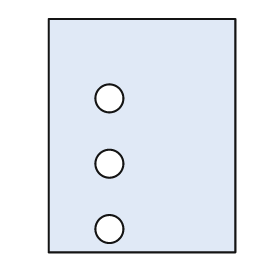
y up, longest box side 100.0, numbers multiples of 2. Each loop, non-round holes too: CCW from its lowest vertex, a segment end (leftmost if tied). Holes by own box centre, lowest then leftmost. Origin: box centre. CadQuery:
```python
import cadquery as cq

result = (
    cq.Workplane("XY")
    .moveTo(-40.0, -50.0)
    .lineTo(40.0, -50.0)
    .lineTo(40.0, 50.0)
    .lineTo(-40.0, 50.0)
    .close()
    .moveTo(-14.0, -40.0)
    .circle(6.0)
    .moveTo(-14.0, -12.0)
    .circle(6.0)
    .moveTo(-14.0, 16.0)
    .circle(6.0)
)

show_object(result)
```